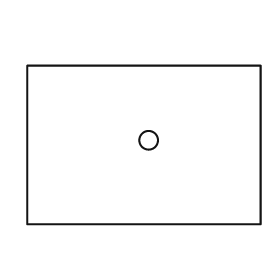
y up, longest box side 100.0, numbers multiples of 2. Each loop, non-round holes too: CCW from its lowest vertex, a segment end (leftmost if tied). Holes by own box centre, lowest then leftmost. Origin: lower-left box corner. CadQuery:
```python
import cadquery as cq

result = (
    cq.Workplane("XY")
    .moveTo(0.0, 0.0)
    .lineTo(100.0, 0.0)
    .lineTo(100.0, 68.0)
    .lineTo(0.0, 68.0)
    .close()
    .moveTo(52.0, 36.0)
    .circle(4.0)
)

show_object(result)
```